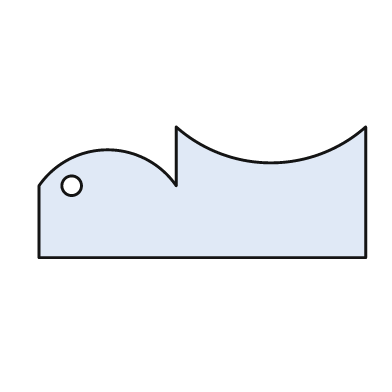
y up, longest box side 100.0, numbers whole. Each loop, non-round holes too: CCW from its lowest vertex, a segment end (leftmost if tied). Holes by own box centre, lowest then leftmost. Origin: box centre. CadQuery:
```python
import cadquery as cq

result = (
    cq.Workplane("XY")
    .moveTo(-50.0, -20.0)
    .lineTo(50.0, -20.0)
    .lineTo(50.0, 20.0)
    .threePointArc((21.0, 9.0), (-8.0, 20.0))
    .lineTo(-8.0, 2.0)
    .threePointArc((-29.0, 13.0), (-50.0, 2.0))
    .close()
    .moveTo(-40.0, 2.0)
    .circle(3.0)
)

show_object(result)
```